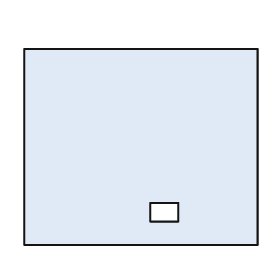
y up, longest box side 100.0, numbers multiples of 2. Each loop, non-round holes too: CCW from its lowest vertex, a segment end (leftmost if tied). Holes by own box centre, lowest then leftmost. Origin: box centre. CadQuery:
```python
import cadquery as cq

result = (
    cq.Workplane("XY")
    .moveTo(-50.0, -42.0)
    .lineTo(50.0, -42.0)
    .lineTo(50.0, 42.0)
    .lineTo(-50.0, 42.0)
    .close()
    .moveTo(4.0, -32.0)
    .lineTo(16.0, -32.0)
    .lineTo(16.0, -24.0)
    .lineTo(4.0, -24.0)
    .close()
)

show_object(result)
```